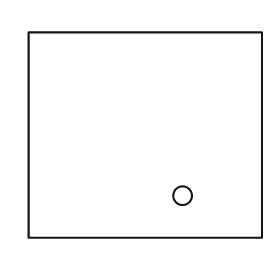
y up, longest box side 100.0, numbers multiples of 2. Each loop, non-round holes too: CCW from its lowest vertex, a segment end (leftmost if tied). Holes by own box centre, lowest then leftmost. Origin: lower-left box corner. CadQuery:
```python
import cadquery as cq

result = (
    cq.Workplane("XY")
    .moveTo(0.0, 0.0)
    .lineTo(100.0, 0.0)
    .lineTo(100.0, 88.0)
    .lineTo(0.0, 88.0)
    .close()
    .moveTo(66.0, 18.0)
    .circle(4.0)
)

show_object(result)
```